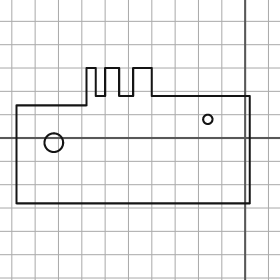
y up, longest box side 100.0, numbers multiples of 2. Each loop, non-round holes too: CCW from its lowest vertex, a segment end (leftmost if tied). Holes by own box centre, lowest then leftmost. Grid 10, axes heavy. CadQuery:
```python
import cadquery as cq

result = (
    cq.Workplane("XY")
    .moveTo(-98.0, -28.0)
    .lineTo(2.0, -28.0)
    .lineTo(2.0, 18.0)
    .lineTo(-40.0, 18.0)
    .lineTo(-40.0, 30.0)
    .lineTo(-48.0, 30.0)
    .lineTo(-48.0, 18.0)
    .lineTo(-54.0, 18.0)
    .lineTo(-54.0, 30.0)
    .lineTo(-60.0, 30.0)
    .lineTo(-60.0, 18.0)
    .lineTo(-64.0, 18.0)
    .lineTo(-64.0, 30.0)
    .lineTo(-68.0, 30.0)
    .lineTo(-68.0, 14.0)
    .lineTo(-98.0, 14.0)
    .close()
    .moveTo(-82.0, -2.0)
    .circle(4.0)
    .moveTo(-16.0, 8.0)
    .circle(2.0)
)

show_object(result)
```